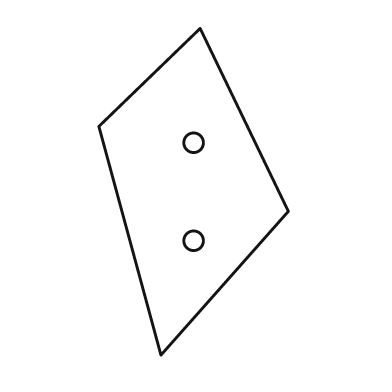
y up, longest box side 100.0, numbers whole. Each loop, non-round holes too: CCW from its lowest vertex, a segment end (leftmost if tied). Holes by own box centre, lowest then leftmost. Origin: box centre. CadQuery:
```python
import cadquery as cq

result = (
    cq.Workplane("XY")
    .moveTo(-10.0, -50.0)
    .lineTo(29.0, -6.0)
    .lineTo(2.0, 50.0)
    .lineTo(-29.0, 20.0)
    .close()
    .moveTo(0.0, -15.0)
    .circle(3.0)
    .moveTo(0.0, 15.0)
    .circle(3.0)
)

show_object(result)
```